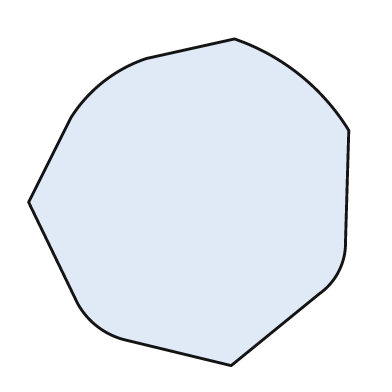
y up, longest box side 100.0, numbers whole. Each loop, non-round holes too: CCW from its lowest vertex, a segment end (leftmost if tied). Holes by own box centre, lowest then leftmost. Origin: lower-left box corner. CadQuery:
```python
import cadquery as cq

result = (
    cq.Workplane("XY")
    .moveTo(62.0, 0.0)
    .lineTo(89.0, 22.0)
    .threePointArc((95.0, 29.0), (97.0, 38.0))
    .lineTo(98.0, 72.0)
    .threePointArc((83.0, 89.0), (63.0, 100.0))
    .lineTo(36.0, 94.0)
    .threePointArc((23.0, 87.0), (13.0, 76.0))
    .lineTo(0.0, 50.0)
    .lineTo(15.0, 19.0)
    .threePointArc((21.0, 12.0), (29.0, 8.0))
    .close()
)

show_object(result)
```